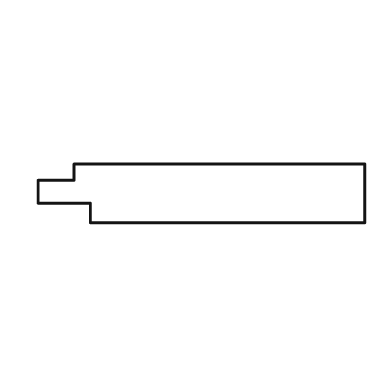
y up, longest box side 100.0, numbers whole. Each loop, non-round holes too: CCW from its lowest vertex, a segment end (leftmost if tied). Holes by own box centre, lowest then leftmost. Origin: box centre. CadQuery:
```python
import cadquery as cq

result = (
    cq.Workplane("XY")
    .moveTo(-34.0, -9.0)
    .lineTo(50.0, -9.0)
    .lineTo(50.0, 9.0)
    .lineTo(-39.0, 9.0)
    .lineTo(-39.0, 4.0)
    .lineTo(-50.0, 4.0)
    .lineTo(-50.0, -3.0)
    .lineTo(-34.0, -3.0)
    .close()
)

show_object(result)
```